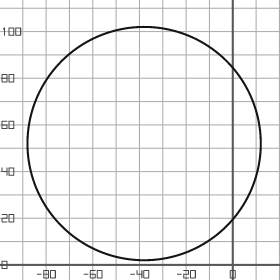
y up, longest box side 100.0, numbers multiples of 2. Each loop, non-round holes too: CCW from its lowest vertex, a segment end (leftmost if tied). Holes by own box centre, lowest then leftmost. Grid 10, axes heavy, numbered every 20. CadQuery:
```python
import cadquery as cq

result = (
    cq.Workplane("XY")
    .moveTo(-38.0, 52.0)
    .circle(50.0)
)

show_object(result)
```